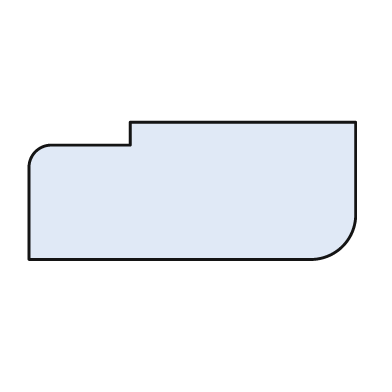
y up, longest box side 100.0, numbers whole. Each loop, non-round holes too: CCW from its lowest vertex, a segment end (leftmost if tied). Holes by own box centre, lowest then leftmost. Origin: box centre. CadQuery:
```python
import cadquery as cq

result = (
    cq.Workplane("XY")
    .moveTo(-50.0, -21.0)
    .lineTo(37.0, -21.0)
    .threePointArc((46.0, -17.0), (50.0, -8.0))
    .lineTo(50.0, 21.0)
    .lineTo(-19.0, 21.0)
    .lineTo(-19.0, 14.0)
    .lineTo(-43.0, 14.0)
    .threePointArc((-48.0, 12.0), (-50.0, 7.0))
    .close()
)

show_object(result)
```